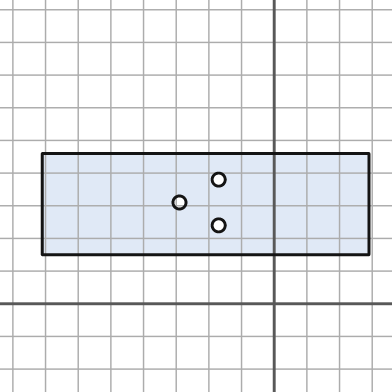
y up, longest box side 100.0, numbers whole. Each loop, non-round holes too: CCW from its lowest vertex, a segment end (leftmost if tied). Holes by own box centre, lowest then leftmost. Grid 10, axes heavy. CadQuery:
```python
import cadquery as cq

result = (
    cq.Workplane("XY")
    .moveTo(-71.0, 15.0)
    .lineTo(29.0, 15.0)
    .lineTo(29.0, 46.0)
    .lineTo(-71.0, 46.0)
    .close()
    .moveTo(-17.0, 24.0)
    .circle(2.0)
    .moveTo(-29.0, 31.0)
    .circle(2.0)
    .moveTo(-17.0, 38.0)
    .circle(2.0)
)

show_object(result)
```